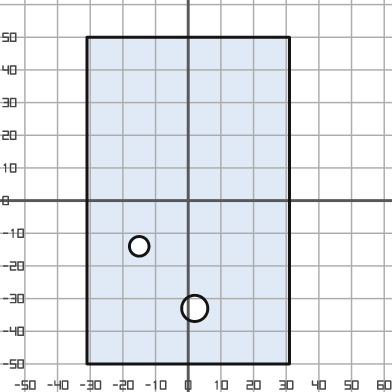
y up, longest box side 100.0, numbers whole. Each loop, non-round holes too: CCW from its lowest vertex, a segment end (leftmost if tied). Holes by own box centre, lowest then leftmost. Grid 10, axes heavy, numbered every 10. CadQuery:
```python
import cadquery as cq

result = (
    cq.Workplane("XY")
    .moveTo(-31.0, -50.0)
    .lineTo(31.0, -50.0)
    .lineTo(31.0, 50.0)
    .lineTo(-31.0, 50.0)
    .close()
    .moveTo(2.0, -33.0)
    .circle(4.0)
    .moveTo(-15.0, -14.0)
    .circle(3.0)
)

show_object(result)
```